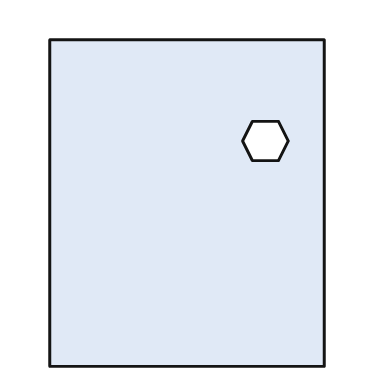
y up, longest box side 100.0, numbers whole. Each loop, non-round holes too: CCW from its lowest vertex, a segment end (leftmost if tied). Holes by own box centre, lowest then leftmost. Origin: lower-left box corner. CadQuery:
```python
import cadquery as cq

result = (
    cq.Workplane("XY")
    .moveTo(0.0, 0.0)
    .lineTo(84.0, 0.0)
    .lineTo(84.0, 100.0)
    .lineTo(0.0, 100.0)
    .close()
    .moveTo(62.0, 63.0)
    .lineTo(70.0, 63.0)
    .lineTo(73.0, 69.0)
    .lineTo(70.0, 75.0)
    .lineTo(62.0, 75.0)
    .lineTo(59.0, 69.0)
    .close()
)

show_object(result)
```